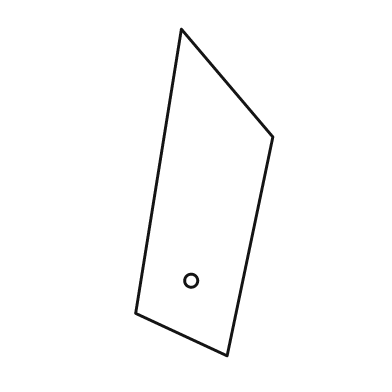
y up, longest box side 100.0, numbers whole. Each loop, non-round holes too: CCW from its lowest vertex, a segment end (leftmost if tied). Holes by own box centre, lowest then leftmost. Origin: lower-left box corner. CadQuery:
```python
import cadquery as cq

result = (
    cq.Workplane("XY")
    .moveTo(28.0, 0.0)
    .lineTo(42.0, 67.0)
    .lineTo(14.0, 100.0)
    .lineTo(0.0, 13.0)
    .close()
    .moveTo(17.0, 23.0)
    .circle(2.0)
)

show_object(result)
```